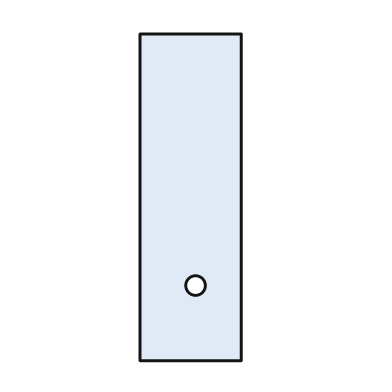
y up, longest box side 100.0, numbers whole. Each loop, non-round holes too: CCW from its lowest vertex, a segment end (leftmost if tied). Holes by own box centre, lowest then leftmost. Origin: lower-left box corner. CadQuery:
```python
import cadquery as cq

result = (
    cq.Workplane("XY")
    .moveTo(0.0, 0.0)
    .lineTo(31.0, 0.0)
    .lineTo(31.0, 100.0)
    .lineTo(0.0, 100.0)
    .close()
    .moveTo(17.0, 23.0)
    .circle(3.0)
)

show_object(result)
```